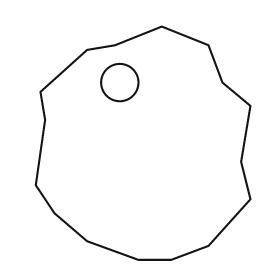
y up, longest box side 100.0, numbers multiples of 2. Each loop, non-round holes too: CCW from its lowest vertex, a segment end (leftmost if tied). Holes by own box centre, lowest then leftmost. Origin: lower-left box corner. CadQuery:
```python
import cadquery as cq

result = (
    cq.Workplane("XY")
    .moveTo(44.0, 0.0)
    .lineTo(58.0, 0.0)
    .lineTo(74.0, 6.0)
    .lineTo(92.0, 26.0)
    .lineTo(88.0, 42.0)
    .lineTo(92.0, 66.0)
    .lineTo(80.0, 76.0)
    .lineTo(74.0, 92.0)
    .lineTo(54.0, 100.0)
    .lineTo(34.0, 92.0)
    .lineTo(22.0, 90.0)
    .lineTo(2.0, 72.0)
    .lineTo(4.0, 60.0)
    .lineTo(0.0, 32.0)
    .lineTo(8.0, 20.0)
    .lineTo(22.0, 8.0)
    .close()
    .moveTo(36.0, 76.0)
    .circle(8.0)
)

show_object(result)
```